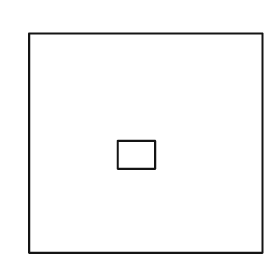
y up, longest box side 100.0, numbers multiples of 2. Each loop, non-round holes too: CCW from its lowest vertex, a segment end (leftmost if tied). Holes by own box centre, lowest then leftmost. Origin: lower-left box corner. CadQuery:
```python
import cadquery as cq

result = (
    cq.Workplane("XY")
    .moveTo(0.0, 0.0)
    .lineTo(100.0, 0.0)
    .lineTo(100.0, 94.0)
    .lineTo(0.0, 94.0)
    .close()
    .moveTo(38.0, 36.0)
    .lineTo(54.0, 36.0)
    .lineTo(54.0, 48.0)
    .lineTo(38.0, 48.0)
    .close()
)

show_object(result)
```